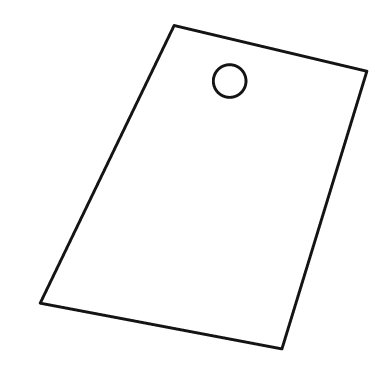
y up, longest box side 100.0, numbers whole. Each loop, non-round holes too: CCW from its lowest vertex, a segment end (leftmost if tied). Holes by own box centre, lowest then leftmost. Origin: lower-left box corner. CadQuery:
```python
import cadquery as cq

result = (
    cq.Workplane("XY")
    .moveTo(74.0, 0.0)
    .lineTo(100.0, 85.0)
    .lineTo(41.0, 99.0)
    .lineTo(0.0, 14.0)
    .close()
    .moveTo(58.0, 82.0)
    .circle(5.0)
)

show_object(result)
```